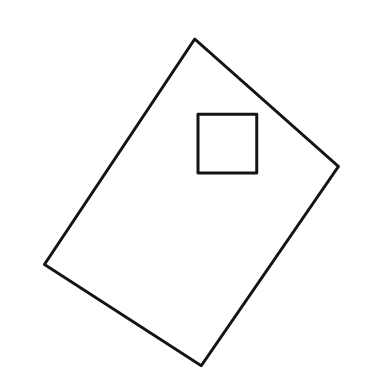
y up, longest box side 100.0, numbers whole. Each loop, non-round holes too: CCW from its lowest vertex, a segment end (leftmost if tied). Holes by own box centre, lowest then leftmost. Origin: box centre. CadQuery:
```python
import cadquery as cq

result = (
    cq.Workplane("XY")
    .moveTo(3.0, -50.0)
    .lineTo(45.0, 11.0)
    .lineTo(1.0, 50.0)
    .lineTo(-45.0, -19.0)
    .close()
    .moveTo(2.0, 9.0)
    .lineTo(20.0, 9.0)
    .lineTo(20.0, 27.0)
    .lineTo(2.0, 27.0)
    .close()
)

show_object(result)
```